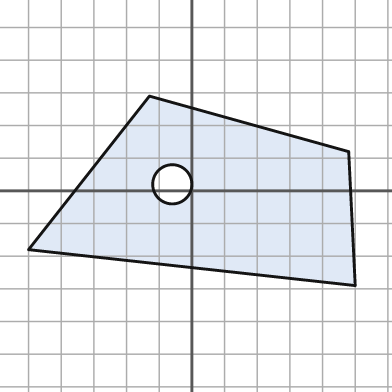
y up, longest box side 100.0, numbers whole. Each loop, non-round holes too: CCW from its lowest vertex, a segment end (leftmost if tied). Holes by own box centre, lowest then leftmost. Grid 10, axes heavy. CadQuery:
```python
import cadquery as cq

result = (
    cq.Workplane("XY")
    .moveTo(50.0, -29.0)
    .lineTo(48.0, 12.0)
    .lineTo(-13.0, 29.0)
    .lineTo(-50.0, -18.0)
    .close()
    .moveTo(-6.0, 2.0)
    .circle(6.0)
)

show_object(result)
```